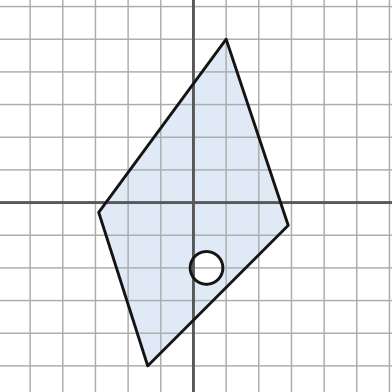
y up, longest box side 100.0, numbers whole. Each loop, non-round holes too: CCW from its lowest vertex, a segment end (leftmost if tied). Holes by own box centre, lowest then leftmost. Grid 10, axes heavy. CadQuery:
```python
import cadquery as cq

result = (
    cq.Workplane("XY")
    .moveTo(-14.0, -50.0)
    .lineTo(29.0, -7.0)
    .lineTo(10.0, 50.0)
    .lineTo(-29.0, -3.0)
    .close()
    .moveTo(4.0, -20.0)
    .circle(5.0)
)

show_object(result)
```